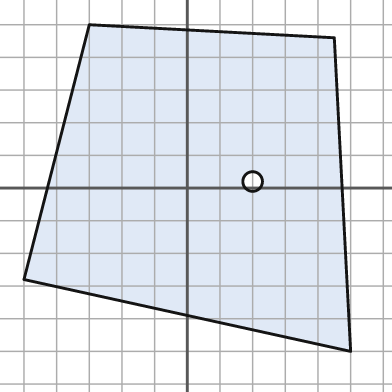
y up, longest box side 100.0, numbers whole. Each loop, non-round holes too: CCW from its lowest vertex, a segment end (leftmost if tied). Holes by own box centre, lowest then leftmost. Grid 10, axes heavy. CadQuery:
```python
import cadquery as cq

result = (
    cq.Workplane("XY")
    .moveTo(50.0, -50.0)
    .lineTo(45.0, 46.0)
    .lineTo(-30.0, 50.0)
    .lineTo(-50.0, -28.0)
    .close()
    .moveTo(20.0, 2.0)
    .circle(3.0)
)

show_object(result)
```